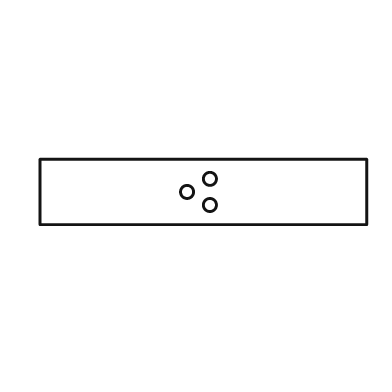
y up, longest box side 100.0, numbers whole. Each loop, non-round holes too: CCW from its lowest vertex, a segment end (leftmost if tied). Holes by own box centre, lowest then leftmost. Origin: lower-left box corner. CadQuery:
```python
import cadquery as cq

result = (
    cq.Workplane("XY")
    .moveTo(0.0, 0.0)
    .lineTo(100.0, 0.0)
    .lineTo(100.0, 20.0)
    .lineTo(0.0, 20.0)
    .close()
    .moveTo(52.0, 6.0)
    .circle(2.0)
    .moveTo(45.0, 10.0)
    .circle(2.0)
    .moveTo(52.0, 14.0)
    .circle(2.0)
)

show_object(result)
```